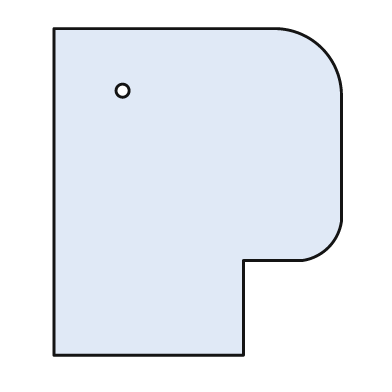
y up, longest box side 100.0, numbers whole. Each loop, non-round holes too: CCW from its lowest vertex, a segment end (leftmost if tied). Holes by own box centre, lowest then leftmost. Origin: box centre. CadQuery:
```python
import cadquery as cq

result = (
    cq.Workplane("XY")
    .moveTo(-44.0, -50.0)
    .lineTo(14.0, -50.0)
    .lineTo(14.0, -21.0)
    .lineTo(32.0, -21.0)
    .threePointArc((40.0, -17.0), (44.0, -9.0))
    .lineTo(44.0, 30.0)
    .threePointArc((38.0, 44.0), (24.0, 50.0))
    .lineTo(-44.0, 50.0)
    .close()
    .moveTo(-23.0, 31.0)
    .circle(2.0)
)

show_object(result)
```